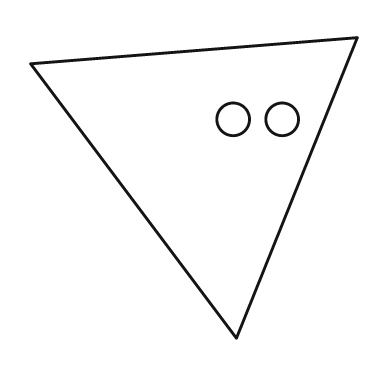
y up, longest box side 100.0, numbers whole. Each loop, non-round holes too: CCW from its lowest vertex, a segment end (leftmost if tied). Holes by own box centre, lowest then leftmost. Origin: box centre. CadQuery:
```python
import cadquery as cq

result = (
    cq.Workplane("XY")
    .moveTo(13.0, -46.0)
    .lineTo(50.0, 46.0)
    .lineTo(-50.0, 38.0)
    .close()
    .moveTo(12.0, 21.0)
    .circle(5.0)
    .moveTo(27.0, 21.0)
    .circle(5.0)
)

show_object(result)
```